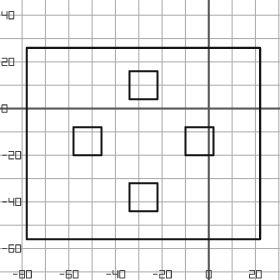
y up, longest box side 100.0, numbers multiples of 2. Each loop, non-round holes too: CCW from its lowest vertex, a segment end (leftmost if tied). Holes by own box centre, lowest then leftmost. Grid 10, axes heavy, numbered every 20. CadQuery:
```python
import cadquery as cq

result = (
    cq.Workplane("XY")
    .moveTo(-78.0, -56.0)
    .lineTo(22.0, -56.0)
    .lineTo(22.0, 26.0)
    .lineTo(-78.0, 26.0)
    .close()
    .moveTo(-34.0, -44.0)
    .lineTo(-22.0, -44.0)
    .lineTo(-22.0, -32.0)
    .lineTo(-34.0, -32.0)
    .close()
    .moveTo(-58.0, -20.0)
    .lineTo(-46.0, -20.0)
    .lineTo(-46.0, -8.0)
    .lineTo(-58.0, -8.0)
    .close()
    .moveTo(-10.0, -20.0)
    .lineTo(2.0, -20.0)
    .lineTo(2.0, -8.0)
    .lineTo(-10.0, -8.0)
    .close()
    .moveTo(-34.0, 4.0)
    .lineTo(-22.0, 4.0)
    .lineTo(-22.0, 16.0)
    .lineTo(-34.0, 16.0)
    .close()
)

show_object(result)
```